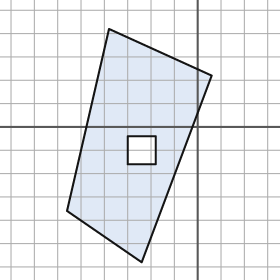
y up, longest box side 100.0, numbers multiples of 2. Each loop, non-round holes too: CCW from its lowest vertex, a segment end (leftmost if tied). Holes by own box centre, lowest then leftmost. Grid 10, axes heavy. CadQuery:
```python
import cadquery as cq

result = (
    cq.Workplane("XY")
    .moveTo(-24.0, -58.0)
    .lineTo(6.0, 22.0)
    .lineTo(-38.0, 42.0)
    .lineTo(-56.0, -36.0)
    .close()
    .moveTo(-30.0, -16.0)
    .lineTo(-18.0, -16.0)
    .lineTo(-18.0, -4.0)
    .lineTo(-30.0, -4.0)
    .close()
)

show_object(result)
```